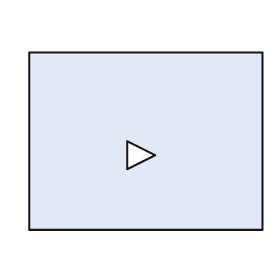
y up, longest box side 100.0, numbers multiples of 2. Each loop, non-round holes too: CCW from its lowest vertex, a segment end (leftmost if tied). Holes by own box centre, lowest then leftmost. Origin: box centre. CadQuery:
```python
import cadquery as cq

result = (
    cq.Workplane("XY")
    .moveTo(-50.0, -38.0)
    .lineTo(50.0, -38.0)
    .lineTo(50.0, 38.0)
    .lineTo(-50.0, 38.0)
    .close()
    .moveTo(-8.0, -12.0)
    .lineTo(4.0, -6.0)
    .lineTo(-8.0, 0.0)
    .close()
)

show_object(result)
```